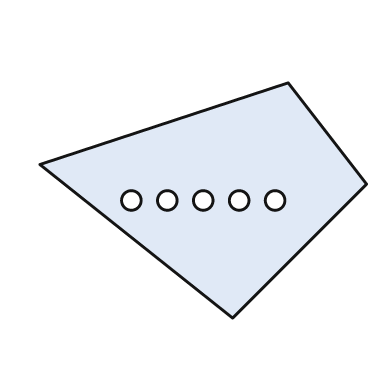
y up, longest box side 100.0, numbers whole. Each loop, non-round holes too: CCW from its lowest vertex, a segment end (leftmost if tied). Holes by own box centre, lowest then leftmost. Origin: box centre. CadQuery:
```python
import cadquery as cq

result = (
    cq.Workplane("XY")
    .moveTo(9.0, -36.0)
    .lineTo(50.0, 5.0)
    .lineTo(26.0, 36.0)
    .lineTo(-50.0, 11.0)
    .close()
    .moveTo(-22.0, 0.0)
    .circle(3.0)
    .moveTo(-11.0, 0.0)
    .circle(3.0)
    .moveTo(0.0, 0.0)
    .circle(3.0)
    .moveTo(11.0, 0.0)
    .circle(3.0)
    .moveTo(22.0, 0.0)
    .circle(3.0)
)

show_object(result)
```